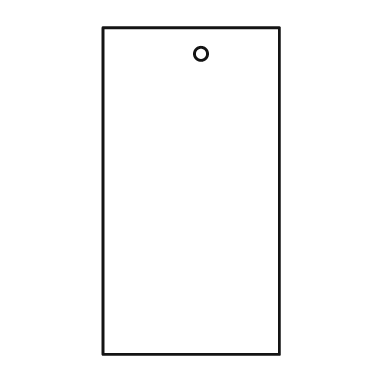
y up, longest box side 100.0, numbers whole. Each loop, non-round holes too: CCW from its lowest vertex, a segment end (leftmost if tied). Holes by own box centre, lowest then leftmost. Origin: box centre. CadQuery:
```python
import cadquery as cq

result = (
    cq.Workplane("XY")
    .moveTo(-27.0, -50.0)
    .lineTo(27.0, -50.0)
    .lineTo(27.0, 50.0)
    .lineTo(-27.0, 50.0)
    .close()
    .moveTo(3.0, 42.0)
    .circle(2.0)
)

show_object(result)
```